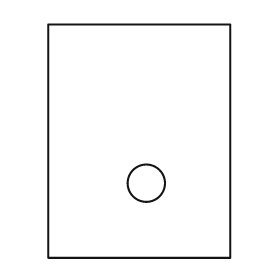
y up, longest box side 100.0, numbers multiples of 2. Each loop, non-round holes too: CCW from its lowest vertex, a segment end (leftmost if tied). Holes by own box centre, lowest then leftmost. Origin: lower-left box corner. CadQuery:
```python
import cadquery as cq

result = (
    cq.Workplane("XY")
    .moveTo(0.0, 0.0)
    .lineTo(78.0, 0.0)
    .lineTo(78.0, 100.0)
    .lineTo(0.0, 100.0)
    .close()
    .moveTo(42.0, 32.0)
    .circle(8.0)
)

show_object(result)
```